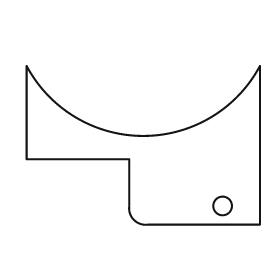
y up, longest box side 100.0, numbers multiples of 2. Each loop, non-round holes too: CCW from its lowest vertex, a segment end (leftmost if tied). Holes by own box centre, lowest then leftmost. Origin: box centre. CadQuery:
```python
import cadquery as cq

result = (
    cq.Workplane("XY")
    .moveTo(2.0, -34.0)
    .lineTo(50.0, -34.0)
    .lineTo(50.0, 34.0)
    .threePointArc((0.0, 4.0), (-50.0, 34.0))
    .lineTo(-50.0, -6.0)
    .lineTo(-6.0, -6.0)
    .lineTo(-6.0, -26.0)
    .threePointArc((-4.0, -32.0), (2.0, -34.0))
    .close()
    .moveTo(34.0, -26.0)
    .circle(4.0)
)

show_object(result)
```